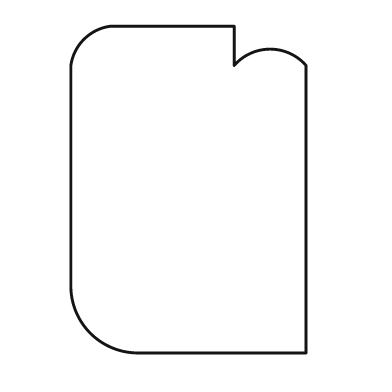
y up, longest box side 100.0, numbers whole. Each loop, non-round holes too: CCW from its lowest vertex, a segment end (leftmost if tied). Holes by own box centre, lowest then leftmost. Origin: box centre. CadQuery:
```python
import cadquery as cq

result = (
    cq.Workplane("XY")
    .moveTo(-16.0, -50.0)
    .lineTo(36.0, -50.0)
    .lineTo(36.0, 38.0)
    .threePointArc((25.0, 43.0), (14.0, 38.0))
    .lineTo(14.0, 50.0)
    .lineTo(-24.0, 50.0)
    .threePointArc((-32.0, 46.0), (-36.0, 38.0))
    .lineTo(-36.0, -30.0)
    .threePointArc((-30.0, -44.0), (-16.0, -50.0))
    .close()
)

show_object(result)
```